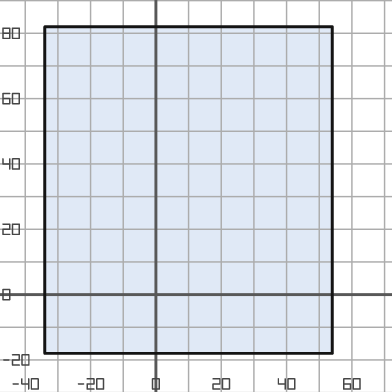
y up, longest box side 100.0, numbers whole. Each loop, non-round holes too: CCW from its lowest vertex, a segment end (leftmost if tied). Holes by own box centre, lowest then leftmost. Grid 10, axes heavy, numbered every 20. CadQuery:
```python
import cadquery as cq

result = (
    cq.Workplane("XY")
    .moveTo(-34.0, -18.0)
    .lineTo(54.0, -18.0)
    .lineTo(54.0, 82.0)
    .lineTo(-34.0, 82.0)
    .close()
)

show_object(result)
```